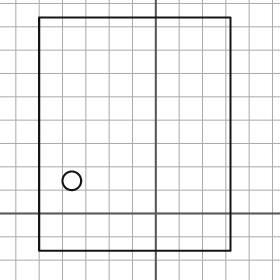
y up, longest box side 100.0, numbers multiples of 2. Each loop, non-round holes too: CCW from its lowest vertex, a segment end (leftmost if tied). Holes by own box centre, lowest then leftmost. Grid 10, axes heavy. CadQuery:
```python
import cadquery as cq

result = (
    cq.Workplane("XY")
    .moveTo(-50.0, -16.0)
    .lineTo(32.0, -16.0)
    .lineTo(32.0, 84.0)
    .lineTo(-50.0, 84.0)
    .close()
    .moveTo(-36.0, 14.0)
    .circle(4.0)
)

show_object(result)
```